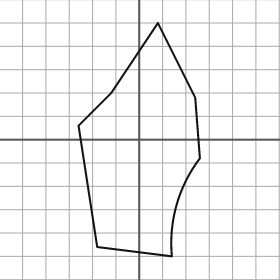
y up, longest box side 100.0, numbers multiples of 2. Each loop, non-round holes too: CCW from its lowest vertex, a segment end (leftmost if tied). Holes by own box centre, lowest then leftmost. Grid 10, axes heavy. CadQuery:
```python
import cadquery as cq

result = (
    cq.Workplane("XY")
    .moveTo(14.0, -50.0)
    .threePointArc((16.0, -28.0), (26.0, -8.0))
    .lineTo(24.0, 18.0)
    .lineTo(8.0, 50.0)
    .lineTo(-12.0, 20.0)
    .lineTo(-26.0, 6.0)
    .lineTo(-18.0, -46.0)
    .close()
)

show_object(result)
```